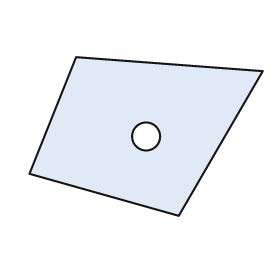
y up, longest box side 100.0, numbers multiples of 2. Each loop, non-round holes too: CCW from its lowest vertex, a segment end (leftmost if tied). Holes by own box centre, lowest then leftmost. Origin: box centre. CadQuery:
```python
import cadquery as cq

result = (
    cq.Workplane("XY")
    .moveTo(14.0, -34.0)
    .lineTo(50.0, 28.0)
    .lineTo(-30.0, 34.0)
    .lineTo(-50.0, -16.0)
    .close()
    .moveTo(0.0, 0.0)
    .circle(6.0)
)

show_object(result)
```